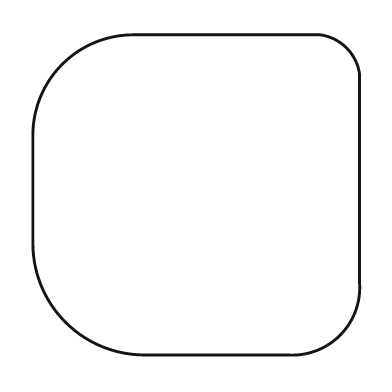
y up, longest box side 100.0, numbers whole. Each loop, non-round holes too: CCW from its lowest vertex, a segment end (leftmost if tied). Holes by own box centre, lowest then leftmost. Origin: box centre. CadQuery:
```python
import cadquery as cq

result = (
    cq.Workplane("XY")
    .moveTo(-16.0, -49.0)
    .lineTo(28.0, -49.0)
    .threePointArc((44.0, -43.0), (50.0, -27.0))
    .lineTo(50.0, 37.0)
    .threePointArc((46.0, 45.0), (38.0, 49.0))
    .lineTo(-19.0, 49.0)
    .threePointArc((-41.0, 40.0), (-50.0, 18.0))
    .lineTo(-50.0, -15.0)
    .threePointArc((-40.0, -39.0), (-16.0, -49.0))
    .close()
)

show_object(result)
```